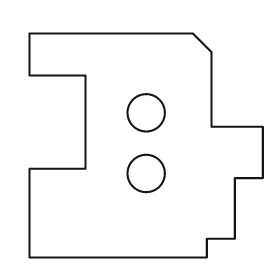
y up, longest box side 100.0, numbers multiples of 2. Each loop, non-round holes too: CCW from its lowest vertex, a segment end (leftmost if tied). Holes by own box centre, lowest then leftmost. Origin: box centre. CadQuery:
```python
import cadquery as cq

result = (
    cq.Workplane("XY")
    .moveTo(-50.0, -48.0)
    .lineTo(26.0, -48.0)
    .lineTo(26.0, -40.0)
    .lineTo(38.0, -40.0)
    .lineTo(38.0, -14.0)
    .lineTo(50.0, -14.0)
    .lineTo(50.0, 8.0)
    .lineTo(28.0, 8.0)
    .lineTo(28.0, 40.0)
    .lineTo(20.0, 48.0)
    .lineTo(-50.0, 48.0)
    .lineTo(-50.0, 30.0)
    .lineTo(-26.0, 30.0)
    .lineTo(-26.0, -10.0)
    .lineTo(-50.0, -10.0)
    .close()
    .moveTo(0.0, -12.0)
    .circle(8.0)
    .moveTo(0.0, 14.0)
    .circle(8.0)
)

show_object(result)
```